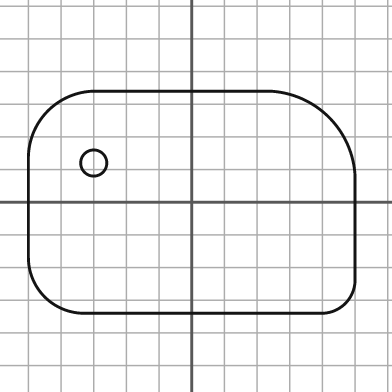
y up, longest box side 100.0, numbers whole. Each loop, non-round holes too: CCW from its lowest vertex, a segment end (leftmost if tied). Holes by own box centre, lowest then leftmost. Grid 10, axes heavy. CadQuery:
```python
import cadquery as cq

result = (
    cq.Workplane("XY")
    .moveTo(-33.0, -34.0)
    .lineTo(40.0, -34.0)
    .threePointArc((47.0, -31.0), (50.0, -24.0))
    .lineTo(50.0, 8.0)
    .threePointArc((42.0, 26.0), (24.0, 34.0))
    .lineTo(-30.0, 34.0)
    .threePointArc((-44.0, 28.0), (-50.0, 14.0))
    .lineTo(-50.0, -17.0)
    .threePointArc((-45.0, -29.0), (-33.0, -34.0))
    .close()
    .moveTo(-30.0, 12.0)
    .circle(4.0)
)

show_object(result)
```